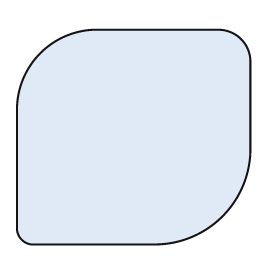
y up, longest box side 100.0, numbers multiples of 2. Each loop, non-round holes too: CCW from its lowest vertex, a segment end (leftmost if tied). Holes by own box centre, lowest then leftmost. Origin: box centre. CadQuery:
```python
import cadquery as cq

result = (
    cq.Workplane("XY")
    .moveTo(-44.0, -46.0)
    .lineTo(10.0, -46.0)
    .threePointArc((38.0, -34.0), (50.0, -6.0))
    .lineTo(50.0, 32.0)
    .threePointArc((46.0, 42.0), (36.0, 46.0))
    .lineTo(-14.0, 46.0)
    .threePointArc((-40.0, 36.0), (-50.0, 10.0))
    .lineTo(-50.0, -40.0)
    .threePointArc((-48.0, -44.0), (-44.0, -46.0))
    .close()
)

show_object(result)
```